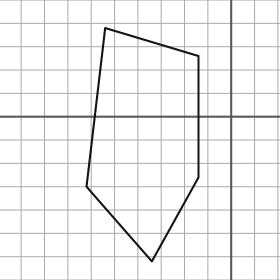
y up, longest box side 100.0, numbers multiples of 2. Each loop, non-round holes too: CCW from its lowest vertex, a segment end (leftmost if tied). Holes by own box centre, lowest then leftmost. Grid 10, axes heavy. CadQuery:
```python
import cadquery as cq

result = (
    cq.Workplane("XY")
    .moveTo(-34.0, -62.0)
    .lineTo(-14.0, -26.0)
    .lineTo(-14.0, 26.0)
    .lineTo(-54.0, 38.0)
    .lineTo(-62.0, -30.0)
    .close()
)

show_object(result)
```